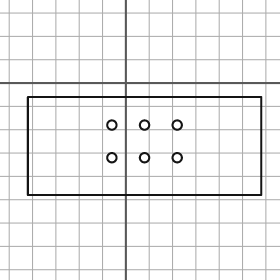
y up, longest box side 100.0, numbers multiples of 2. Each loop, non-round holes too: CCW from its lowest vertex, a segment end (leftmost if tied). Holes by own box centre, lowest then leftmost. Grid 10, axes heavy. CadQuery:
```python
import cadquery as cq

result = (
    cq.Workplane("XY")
    .moveTo(-42.0, -48.0)
    .lineTo(58.0, -48.0)
    .lineTo(58.0, -6.0)
    .lineTo(-42.0, -6.0)
    .close()
    .moveTo(-6.0, -32.0)
    .circle(2.0)
    .moveTo(8.0, -32.0)
    .circle(2.0)
    .moveTo(22.0, -32.0)
    .circle(2.0)
    .moveTo(-6.0, -18.0)
    .circle(2.0)
    .moveTo(8.0, -18.0)
    .circle(2.0)
    .moveTo(22.0, -18.0)
    .circle(2.0)
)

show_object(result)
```